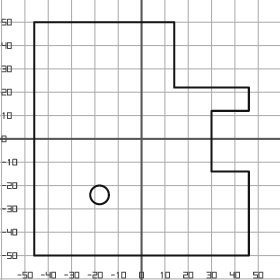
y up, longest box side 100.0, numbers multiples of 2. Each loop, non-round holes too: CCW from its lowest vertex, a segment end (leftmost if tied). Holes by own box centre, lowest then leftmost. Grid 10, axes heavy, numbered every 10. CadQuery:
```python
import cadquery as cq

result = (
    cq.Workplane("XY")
    .moveTo(-46.0, -50.0)
    .lineTo(46.0, -50.0)
    .lineTo(46.0, -14.0)
    .lineTo(30.0, -14.0)
    .lineTo(30.0, 12.0)
    .lineTo(46.0, 12.0)
    .lineTo(46.0, 22.0)
    .lineTo(14.0, 22.0)
    .lineTo(14.0, 50.0)
    .lineTo(-46.0, 50.0)
    .close()
    .moveTo(-18.0, -24.0)
    .circle(4.0)
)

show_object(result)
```